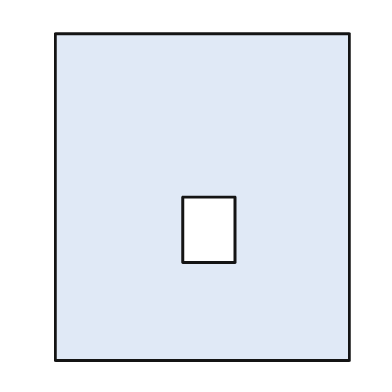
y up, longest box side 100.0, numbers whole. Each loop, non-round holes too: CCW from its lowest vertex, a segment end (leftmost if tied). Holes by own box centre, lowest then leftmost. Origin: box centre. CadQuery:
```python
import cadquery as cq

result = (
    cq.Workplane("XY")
    .moveTo(-45.0, -50.0)
    .lineTo(45.0, -50.0)
    .lineTo(45.0, 50.0)
    .lineTo(-45.0, 50.0)
    .close()
    .moveTo(-6.0, -20.0)
    .lineTo(10.0, -20.0)
    .lineTo(10.0, 0.0)
    .lineTo(-6.0, 0.0)
    .close()
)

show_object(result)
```